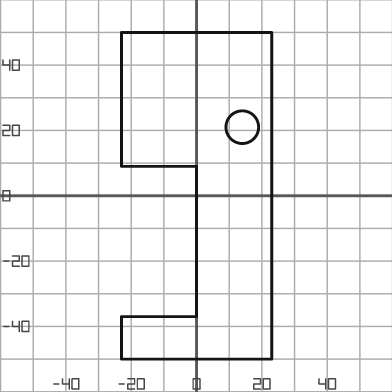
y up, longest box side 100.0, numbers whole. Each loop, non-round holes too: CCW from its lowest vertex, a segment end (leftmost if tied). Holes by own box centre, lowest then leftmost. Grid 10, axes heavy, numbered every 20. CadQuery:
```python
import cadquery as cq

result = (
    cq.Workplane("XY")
    .moveTo(-23.0, -50.0)
    .lineTo(23.0, -50.0)
    .lineTo(23.0, 50.0)
    .lineTo(-23.0, 50.0)
    .lineTo(-23.0, 9.0)
    .lineTo(0.0, 9.0)
    .lineTo(0.0, -37.0)
    .lineTo(-23.0, -37.0)
    .close()
    .moveTo(14.0, 21.0)
    .circle(5.0)
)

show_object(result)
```